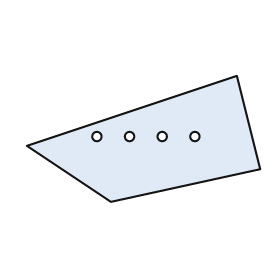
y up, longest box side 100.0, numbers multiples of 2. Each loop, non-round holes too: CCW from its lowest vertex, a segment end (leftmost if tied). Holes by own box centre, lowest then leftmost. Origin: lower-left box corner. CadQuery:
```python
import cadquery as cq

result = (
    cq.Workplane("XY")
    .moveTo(36.0, 0.0)
    .lineTo(100.0, 14.0)
    .lineTo(90.0, 54.0)
    .lineTo(0.0, 24.0)
    .close()
    .moveTo(30.0, 28.0)
    .circle(2.0)
    .moveTo(44.0, 28.0)
    .circle(2.0)
    .moveTo(58.0, 28.0)
    .circle(2.0)
    .moveTo(72.0, 28.0)
    .circle(2.0)
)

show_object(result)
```